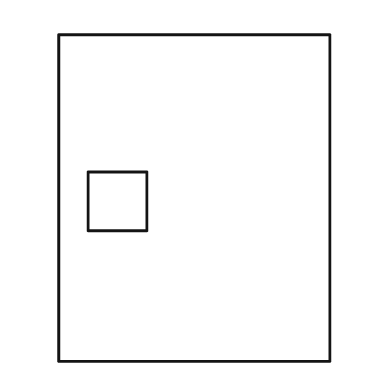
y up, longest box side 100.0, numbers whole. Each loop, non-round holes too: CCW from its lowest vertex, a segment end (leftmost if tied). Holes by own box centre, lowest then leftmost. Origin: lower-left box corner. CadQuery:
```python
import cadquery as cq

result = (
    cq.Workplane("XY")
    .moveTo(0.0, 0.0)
    .lineTo(83.0, 0.0)
    .lineTo(83.0, 100.0)
    .lineTo(0.0, 100.0)
    .close()
    .moveTo(9.0, 40.0)
    .lineTo(27.0, 40.0)
    .lineTo(27.0, 58.0)
    .lineTo(9.0, 58.0)
    .close()
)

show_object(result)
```